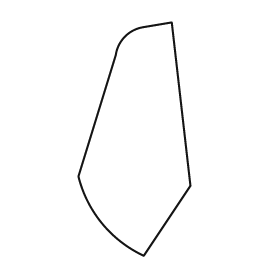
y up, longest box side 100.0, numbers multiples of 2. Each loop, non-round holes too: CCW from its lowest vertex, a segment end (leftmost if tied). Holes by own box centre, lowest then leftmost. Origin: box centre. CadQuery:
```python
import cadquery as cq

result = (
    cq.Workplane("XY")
    .moveTo(4.0, -50.0)
    .lineTo(24.0, -20.0)
    .lineTo(16.0, 50.0)
    .lineTo(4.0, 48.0)
    .threePointArc((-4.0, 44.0), (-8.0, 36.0))
    .lineTo(-24.0, -16.0)
    .threePointArc((-14.0, -36.0), (4.0, -50.0))
    .close()
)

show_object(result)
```